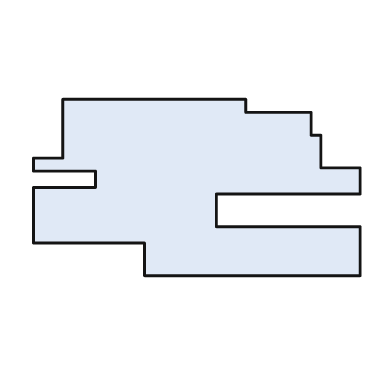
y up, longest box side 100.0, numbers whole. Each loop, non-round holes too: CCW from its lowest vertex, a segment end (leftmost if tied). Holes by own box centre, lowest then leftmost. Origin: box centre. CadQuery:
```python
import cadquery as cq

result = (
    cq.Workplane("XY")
    .moveTo(-16.0, -27.0)
    .lineTo(50.0, -27.0)
    .lineTo(50.0, -12.0)
    .lineTo(6.0, -12.0)
    .lineTo(6.0, -2.0)
    .lineTo(50.0, -2.0)
    .lineTo(50.0, 6.0)
    .lineTo(38.0, 6.0)
    .lineTo(38.0, 16.0)
    .lineTo(35.0, 16.0)
    .lineTo(35.0, 23.0)
    .lineTo(15.0, 23.0)
    .lineTo(15.0, 27.0)
    .lineTo(-41.0, 27.0)
    .lineTo(-41.0, 9.0)
    .lineTo(-50.0, 9.0)
    .lineTo(-50.0, 5.0)
    .lineTo(-31.0, 5.0)
    .lineTo(-31.0, 0.0)
    .lineTo(-50.0, 0.0)
    .lineTo(-50.0, -17.0)
    .lineTo(-16.0, -17.0)
    .close()
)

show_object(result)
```